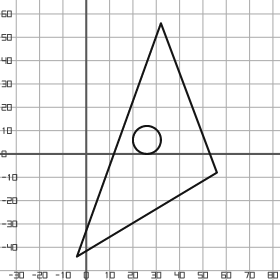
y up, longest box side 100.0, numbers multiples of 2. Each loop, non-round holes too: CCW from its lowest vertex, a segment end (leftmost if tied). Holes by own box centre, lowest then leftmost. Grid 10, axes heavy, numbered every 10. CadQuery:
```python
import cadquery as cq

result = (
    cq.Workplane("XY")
    .moveTo(-4.0, -44.0)
    .lineTo(56.0, -8.0)
    .lineTo(32.0, 56.0)
    .close()
    .moveTo(26.0, 6.0)
    .circle(6.0)
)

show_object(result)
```